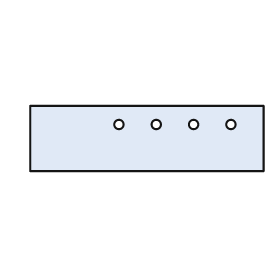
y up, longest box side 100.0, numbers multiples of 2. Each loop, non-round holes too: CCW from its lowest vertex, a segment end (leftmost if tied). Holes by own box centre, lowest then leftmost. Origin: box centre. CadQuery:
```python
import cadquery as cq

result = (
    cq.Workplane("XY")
    .moveTo(-50.0, -14.0)
    .lineTo(50.0, -14.0)
    .lineTo(50.0, 14.0)
    .lineTo(-50.0, 14.0)
    .close()
    .moveTo(-12.0, 6.0)
    .circle(2.0)
    .moveTo(4.0, 6.0)
    .circle(2.0)
    .moveTo(20.0, 6.0)
    .circle(2.0)
    .moveTo(36.0, 6.0)
    .circle(2.0)
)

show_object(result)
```